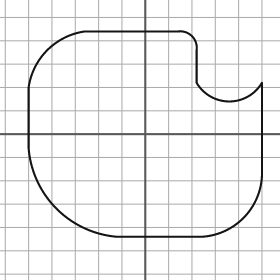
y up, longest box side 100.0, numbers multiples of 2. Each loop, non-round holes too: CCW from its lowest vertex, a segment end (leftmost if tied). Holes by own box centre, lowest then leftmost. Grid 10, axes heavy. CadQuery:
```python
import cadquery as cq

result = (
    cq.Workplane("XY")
    .moveTo(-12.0, -44.0)
    .lineTo(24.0, -44.0)
    .threePointArc((42.0, -36.0), (50.0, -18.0))
    .lineTo(50.0, 22.0)
    .threePointArc((36.0, 14.0), (22.0, 22.0))
    .lineTo(22.0, 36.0)
    .threePointArc((20.0, 42.0), (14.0, 44.0))
    .lineTo(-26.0, 44.0)
    .threePointArc((-42.0, 36.0), (-50.0, 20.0))
    .lineTo(-50.0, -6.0)
    .threePointArc((-38.0, -32.0), (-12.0, -44.0))
    .close()
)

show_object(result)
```